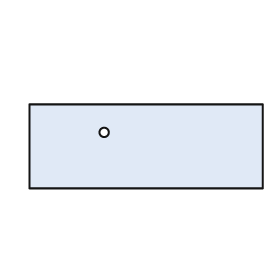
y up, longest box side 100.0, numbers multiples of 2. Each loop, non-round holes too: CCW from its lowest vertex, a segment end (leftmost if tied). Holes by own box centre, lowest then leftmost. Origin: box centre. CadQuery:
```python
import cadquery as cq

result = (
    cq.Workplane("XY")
    .moveTo(-50.0, -18.0)
    .lineTo(50.0, -18.0)
    .lineTo(50.0, 18.0)
    .lineTo(-50.0, 18.0)
    .close()
    .moveTo(-18.0, 6.0)
    .circle(2.0)
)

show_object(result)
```